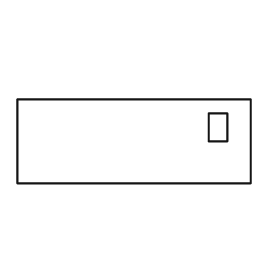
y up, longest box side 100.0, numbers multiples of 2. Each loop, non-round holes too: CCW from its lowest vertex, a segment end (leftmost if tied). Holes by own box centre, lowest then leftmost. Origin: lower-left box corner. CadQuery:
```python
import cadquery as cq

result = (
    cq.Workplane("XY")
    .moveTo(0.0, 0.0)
    .lineTo(100.0, 0.0)
    .lineTo(100.0, 36.0)
    .lineTo(0.0, 36.0)
    .close()
    .moveTo(82.0, 18.0)
    .lineTo(90.0, 18.0)
    .lineTo(90.0, 30.0)
    .lineTo(82.0, 30.0)
    .close()
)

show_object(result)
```